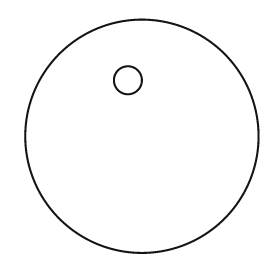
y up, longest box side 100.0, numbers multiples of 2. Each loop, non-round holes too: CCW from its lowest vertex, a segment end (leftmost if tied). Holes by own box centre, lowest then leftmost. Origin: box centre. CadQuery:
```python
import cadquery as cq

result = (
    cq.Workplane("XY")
    .moveTo(0.0, 0.0)
    .circle(50.0)
    .moveTo(-6.0, 24.0)
    .circle(6.0)
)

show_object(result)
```